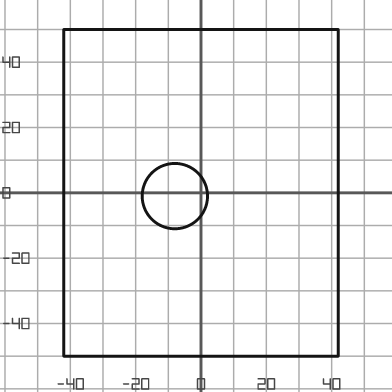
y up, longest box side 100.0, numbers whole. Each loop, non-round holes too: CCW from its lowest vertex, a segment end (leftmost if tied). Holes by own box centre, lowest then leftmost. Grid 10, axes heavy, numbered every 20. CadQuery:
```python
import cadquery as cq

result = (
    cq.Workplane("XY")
    .moveTo(-42.0, -50.0)
    .lineTo(42.0, -50.0)
    .lineTo(42.0, 50.0)
    .lineTo(-42.0, 50.0)
    .close()
    .moveTo(-8.0, -1.0)
    .circle(10.0)
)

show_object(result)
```